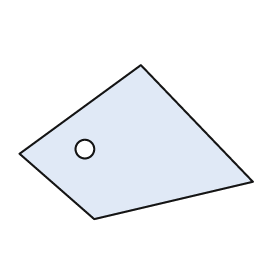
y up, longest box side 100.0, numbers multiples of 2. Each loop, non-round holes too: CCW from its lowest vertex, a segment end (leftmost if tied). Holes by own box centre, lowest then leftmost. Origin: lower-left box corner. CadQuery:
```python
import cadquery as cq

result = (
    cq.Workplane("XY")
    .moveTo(32.0, 0.0)
    .lineTo(100.0, 16.0)
    .lineTo(52.0, 66.0)
    .lineTo(0.0, 28.0)
    .close()
    .moveTo(28.0, 30.0)
    .circle(4.0)
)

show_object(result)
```